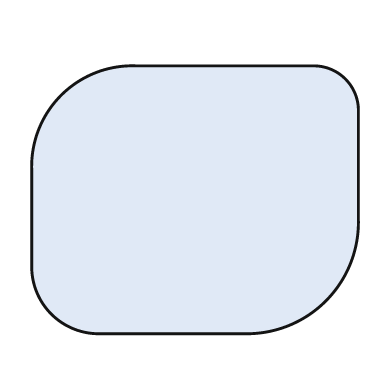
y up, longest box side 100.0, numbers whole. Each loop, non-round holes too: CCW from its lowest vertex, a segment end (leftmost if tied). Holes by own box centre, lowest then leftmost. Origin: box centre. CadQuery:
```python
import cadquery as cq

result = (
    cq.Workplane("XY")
    .moveTo(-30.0, -41.0)
    .lineTo(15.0, -41.0)
    .threePointArc((40.0, -31.0), (50.0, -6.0))
    .lineTo(50.0, 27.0)
    .threePointArc((46.0, 37.0), (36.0, 41.0))
    .lineTo(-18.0, 41.0)
    .threePointArc((-41.0, 32.0), (-50.0, 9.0))
    .lineTo(-50.0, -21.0)
    .threePointArc((-44.0, -35.0), (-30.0, -41.0))
    .close()
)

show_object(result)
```